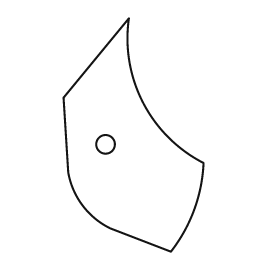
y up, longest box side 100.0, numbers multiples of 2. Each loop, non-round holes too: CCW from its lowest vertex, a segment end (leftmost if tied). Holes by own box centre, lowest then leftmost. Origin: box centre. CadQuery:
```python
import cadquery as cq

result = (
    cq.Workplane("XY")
    .moveTo(16.0, -50.0)
    .threePointArc((26.0, -32.0), (30.0, -12.0))
    .threePointArc((4.0, 14.0), (-2.0, 50.0))
    .lineTo(-30.0, 16.0)
    .lineTo(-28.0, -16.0)
    .threePointArc((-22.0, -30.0), (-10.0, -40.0))
    .close()
    .moveTo(-12.0, -4.0)
    .circle(4.0)
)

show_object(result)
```